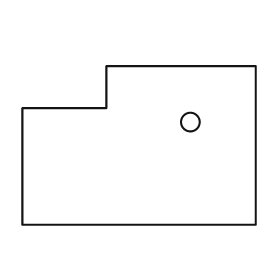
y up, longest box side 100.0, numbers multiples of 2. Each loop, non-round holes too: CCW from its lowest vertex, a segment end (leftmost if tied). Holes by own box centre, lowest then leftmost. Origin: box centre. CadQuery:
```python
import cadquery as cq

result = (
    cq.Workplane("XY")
    .moveTo(-50.0, -34.0)
    .lineTo(50.0, -34.0)
    .lineTo(50.0, 34.0)
    .lineTo(-14.0, 34.0)
    .lineTo(-14.0, 16.0)
    .lineTo(-50.0, 16.0)
    .close()
    .moveTo(22.0, 10.0)
    .circle(4.0)
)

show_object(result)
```